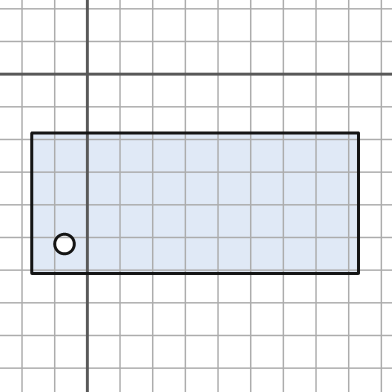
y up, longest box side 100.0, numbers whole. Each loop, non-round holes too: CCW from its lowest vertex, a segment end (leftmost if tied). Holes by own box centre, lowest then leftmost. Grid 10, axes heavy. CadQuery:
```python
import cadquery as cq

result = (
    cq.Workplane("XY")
    .moveTo(-17.0, -61.0)
    .lineTo(83.0, -61.0)
    .lineTo(83.0, -18.0)
    .lineTo(-17.0, -18.0)
    .close()
    .moveTo(-7.0, -52.0)
    .circle(3.0)
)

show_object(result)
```